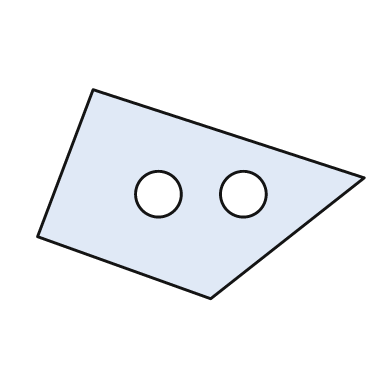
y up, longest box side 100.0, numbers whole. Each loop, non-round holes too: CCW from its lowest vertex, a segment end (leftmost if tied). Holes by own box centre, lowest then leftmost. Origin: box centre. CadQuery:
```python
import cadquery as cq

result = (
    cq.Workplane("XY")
    .moveTo(3.0, -32.0)
    .lineTo(50.0, 5.0)
    .lineTo(-33.0, 32.0)
    .lineTo(-50.0, -13.0)
    .close()
    .moveTo(-13.0, 0.0)
    .circle(7.0)
    .moveTo(13.0, 0.0)
    .circle(7.0)
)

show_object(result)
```